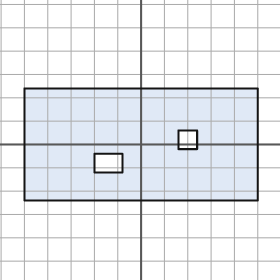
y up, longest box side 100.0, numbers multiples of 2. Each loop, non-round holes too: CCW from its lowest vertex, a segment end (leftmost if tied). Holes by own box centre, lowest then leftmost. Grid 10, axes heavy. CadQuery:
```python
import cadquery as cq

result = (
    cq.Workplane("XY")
    .moveTo(-50.0, -24.0)
    .lineTo(50.0, -24.0)
    .lineTo(50.0, 24.0)
    .lineTo(-50.0, 24.0)
    .close()
    .moveTo(-20.0, -12.0)
    .lineTo(-8.0, -12.0)
    .lineTo(-8.0, -4.0)
    .lineTo(-20.0, -4.0)
    .close()
    .moveTo(16.0, -2.0)
    .lineTo(24.0, -2.0)
    .lineTo(24.0, 6.0)
    .lineTo(16.0, 6.0)
    .close()
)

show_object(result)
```